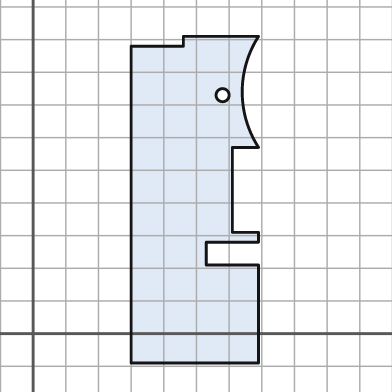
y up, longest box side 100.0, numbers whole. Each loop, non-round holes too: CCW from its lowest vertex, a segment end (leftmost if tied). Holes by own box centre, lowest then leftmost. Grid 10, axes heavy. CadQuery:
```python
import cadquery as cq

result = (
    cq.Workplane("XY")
    .moveTo(30.0, -9.0)
    .lineTo(69.0, -9.0)
    .lineTo(69.0, 21.0)
    .lineTo(53.0, 21.0)
    .lineTo(53.0, 28.0)
    .lineTo(69.0, 28.0)
    .lineTo(69.0, 31.0)
    .lineTo(61.0, 31.0)
    .lineTo(61.0, 57.0)
    .lineTo(69.0, 57.0)
    .threePointArc((64.0, 74.0), (69.0, 91.0))
    .lineTo(46.0, 91.0)
    .lineTo(46.0, 88.0)
    .lineTo(30.0, 88.0)
    .close()
    .moveTo(58.0, 73.0)
    .circle(2.0)
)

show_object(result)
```